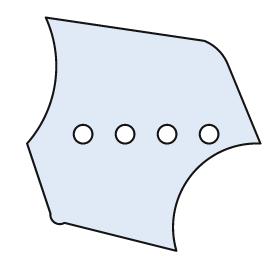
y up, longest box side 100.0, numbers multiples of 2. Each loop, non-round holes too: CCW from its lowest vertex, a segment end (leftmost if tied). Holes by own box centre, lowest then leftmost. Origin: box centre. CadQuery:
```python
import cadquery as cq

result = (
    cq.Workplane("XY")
    .moveTo(14.0, -50.0)
    .threePointArc((20.0, -18.0), (50.0, -4.0))
    .lineTo(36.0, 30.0)
    .threePointArc((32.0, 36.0), (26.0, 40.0))
    .lineTo(-42.0, 50.0)
    .threePointArc((-38.0, 22.0), (-50.0, -4.0))
    .lineTo(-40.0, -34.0)
    .threePointArc((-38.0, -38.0), (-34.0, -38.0))
    .close()
    .moveTo(-26.0, 0.0)
    .circle(4.0)
    .moveTo(-8.0, 0.0)
    .circle(4.0)
    .moveTo(10.0, 0.0)
    .circle(4.0)
    .moveTo(28.0, 0.0)
    .circle(4.0)
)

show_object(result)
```